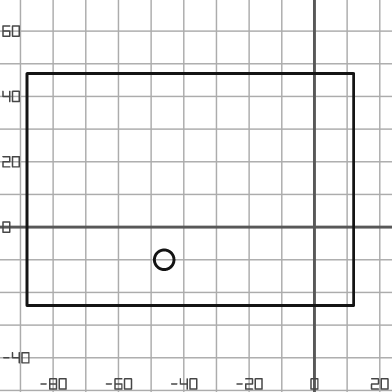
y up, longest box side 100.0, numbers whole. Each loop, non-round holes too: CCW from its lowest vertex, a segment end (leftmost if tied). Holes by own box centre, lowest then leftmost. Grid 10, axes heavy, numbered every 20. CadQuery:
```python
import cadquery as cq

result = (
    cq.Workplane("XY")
    .moveTo(-88.0, -24.0)
    .lineTo(12.0, -24.0)
    .lineTo(12.0, 47.0)
    .lineTo(-88.0, 47.0)
    .close()
    .moveTo(-46.0, -10.0)
    .circle(3.0)
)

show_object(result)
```